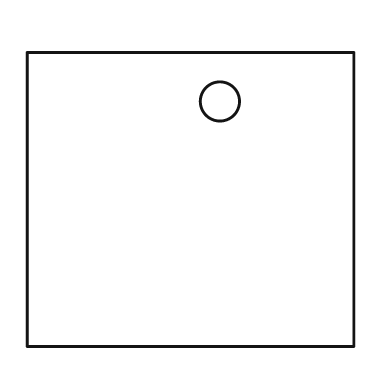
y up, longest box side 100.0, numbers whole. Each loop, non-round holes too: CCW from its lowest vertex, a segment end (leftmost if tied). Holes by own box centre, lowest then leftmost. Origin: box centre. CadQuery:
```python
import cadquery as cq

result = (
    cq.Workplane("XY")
    .moveTo(-50.0, -45.0)
    .lineTo(50.0, -45.0)
    .lineTo(50.0, 45.0)
    .lineTo(-50.0, 45.0)
    .close()
    .moveTo(9.0, 30.0)
    .circle(6.0)
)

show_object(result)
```